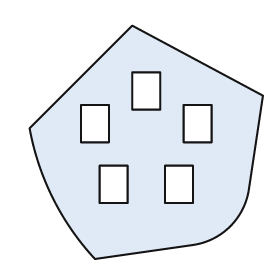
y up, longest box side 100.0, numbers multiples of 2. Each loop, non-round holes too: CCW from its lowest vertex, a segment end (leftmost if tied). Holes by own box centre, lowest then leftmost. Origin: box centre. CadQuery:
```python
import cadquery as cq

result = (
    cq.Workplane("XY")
    .moveTo(-22.0, -50.0)
    .lineTo(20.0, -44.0)
    .threePointArc((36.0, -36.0), (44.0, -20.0))
    .lineTo(50.0, 20.0)
    .lineTo(-6.0, 50.0)
    .lineTo(-50.0, 6.0)
    .threePointArc((-40.0, -24.0), (-22.0, -50.0))
    .close()
    .moveTo(-20.0, -26.0)
    .lineTo(-8.0, -26.0)
    .lineTo(-8.0, -10.0)
    .lineTo(-20.0, -10.0)
    .close()
    .moveTo(8.0, -26.0)
    .lineTo(20.0, -26.0)
    .lineTo(20.0, -10.0)
    .lineTo(8.0, -10.0)
    .close()
    .moveTo(-28.0, 0.0)
    .lineTo(-16.0, 0.0)
    .lineTo(-16.0, 16.0)
    .lineTo(-28.0, 16.0)
    .close()
    .moveTo(16.0, 0.0)
    .lineTo(28.0, 0.0)
    .lineTo(28.0, 16.0)
    .lineTo(16.0, 16.0)
    .close()
    .moveTo(-6.0, 14.0)
    .lineTo(6.0, 14.0)
    .lineTo(6.0, 30.0)
    .lineTo(-6.0, 30.0)
    .close()
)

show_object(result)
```